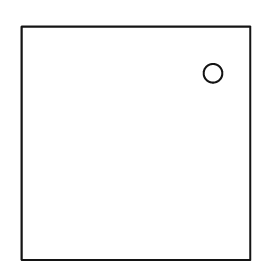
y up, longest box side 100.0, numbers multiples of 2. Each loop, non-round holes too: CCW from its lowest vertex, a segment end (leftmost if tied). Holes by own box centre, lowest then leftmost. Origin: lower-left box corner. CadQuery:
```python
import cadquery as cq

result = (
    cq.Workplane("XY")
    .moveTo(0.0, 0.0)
    .lineTo(98.0, 0.0)
    .lineTo(98.0, 100.0)
    .lineTo(0.0, 100.0)
    .close()
    .moveTo(82.0, 80.0)
    .circle(4.0)
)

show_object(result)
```